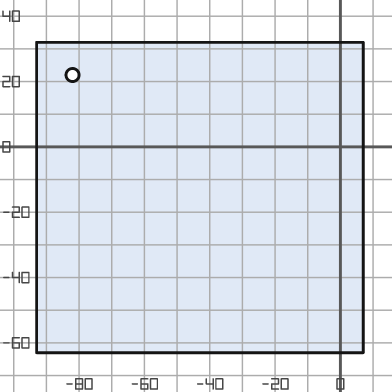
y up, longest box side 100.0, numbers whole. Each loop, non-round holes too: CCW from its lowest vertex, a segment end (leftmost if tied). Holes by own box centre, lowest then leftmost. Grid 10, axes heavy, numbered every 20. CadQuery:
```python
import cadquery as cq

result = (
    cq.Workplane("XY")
    .moveTo(-93.0, -63.0)
    .lineTo(7.0, -63.0)
    .lineTo(7.0, 32.0)
    .lineTo(-93.0, 32.0)
    .close()
    .moveTo(-82.0, 22.0)
    .circle(2.0)
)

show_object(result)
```